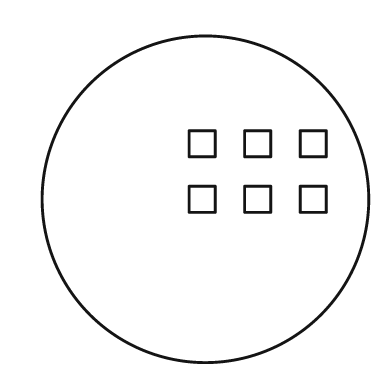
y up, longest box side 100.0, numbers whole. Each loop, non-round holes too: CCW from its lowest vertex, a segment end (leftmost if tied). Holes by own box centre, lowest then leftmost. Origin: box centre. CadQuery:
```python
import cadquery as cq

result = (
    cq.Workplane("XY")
    .moveTo(0.0, 0.0)
    .circle(50.0)
    .moveTo(-5.0, -4.0)
    .lineTo(3.0, -4.0)
    .lineTo(3.0, 4.0)
    .lineTo(-5.0, 4.0)
    .close()
    .moveTo(12.0, -4.0)
    .lineTo(20.0, -4.0)
    .lineTo(20.0, 4.0)
    .lineTo(12.0, 4.0)
    .close()
    .moveTo(29.0, -4.0)
    .lineTo(37.0, -4.0)
    .lineTo(37.0, 4.0)
    .lineTo(29.0, 4.0)
    .close()
    .moveTo(-5.0, 13.0)
    .lineTo(3.0, 13.0)
    .lineTo(3.0, 21.0)
    .lineTo(-5.0, 21.0)
    .close()
    .moveTo(12.0, 13.0)
    .lineTo(20.0, 13.0)
    .lineTo(20.0, 21.0)
    .lineTo(12.0, 21.0)
    .close()
    .moveTo(29.0, 13.0)
    .lineTo(37.0, 13.0)
    .lineTo(37.0, 21.0)
    .lineTo(29.0, 21.0)
    .close()
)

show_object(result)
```